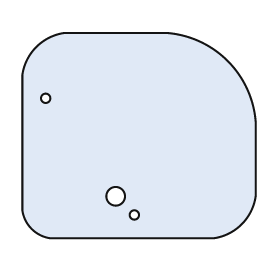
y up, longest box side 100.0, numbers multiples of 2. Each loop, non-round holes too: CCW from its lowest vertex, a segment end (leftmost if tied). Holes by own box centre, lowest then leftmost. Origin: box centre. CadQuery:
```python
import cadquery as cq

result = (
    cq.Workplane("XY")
    .moveTo(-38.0, -44.0)
    .lineTo(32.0, -44.0)
    .threePointArc((44.0, -38.0), (50.0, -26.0))
    .lineTo(50.0, 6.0)
    .threePointArc((38.0, 32.0), (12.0, 44.0))
    .lineTo(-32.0, 44.0)
    .threePointArc((-44.0, 38.0), (-50.0, 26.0))
    .lineTo(-50.0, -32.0)
    .threePointArc((-46.0, -40.0), (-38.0, -44.0))
    .close()
    .moveTo(-2.0, -34.0)
    .circle(2.0)
    .moveTo(-10.0, -26.0)
    .circle(4.0)
    .moveTo(-40.0, 16.0)
    .circle(2.0)
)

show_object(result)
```